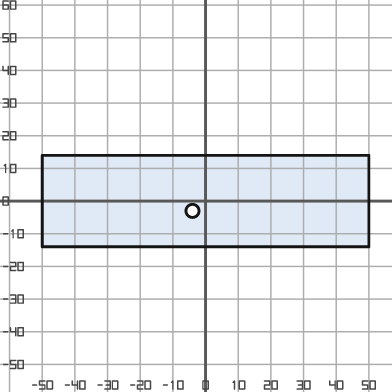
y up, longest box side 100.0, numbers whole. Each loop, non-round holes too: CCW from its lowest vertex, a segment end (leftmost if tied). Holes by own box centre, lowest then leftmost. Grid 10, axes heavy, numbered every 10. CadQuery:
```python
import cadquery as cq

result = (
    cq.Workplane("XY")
    .moveTo(-50.0, -14.0)
    .lineTo(50.0, -14.0)
    .lineTo(50.0, 14.0)
    .lineTo(-50.0, 14.0)
    .close()
    .moveTo(-4.0, -3.0)
    .circle(2.0)
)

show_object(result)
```